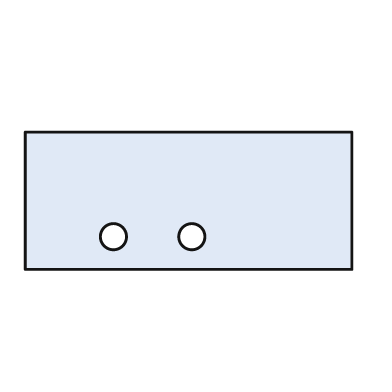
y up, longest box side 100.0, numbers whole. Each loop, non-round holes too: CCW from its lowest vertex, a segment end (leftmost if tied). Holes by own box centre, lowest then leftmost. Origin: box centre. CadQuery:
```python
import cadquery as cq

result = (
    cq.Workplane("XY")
    .moveTo(-50.0, -21.0)
    .lineTo(50.0, -21.0)
    .lineTo(50.0, 21.0)
    .lineTo(-50.0, 21.0)
    .close()
    .moveTo(-23.0, -11.0)
    .circle(4.0)
    .moveTo(1.0, -11.0)
    .circle(4.0)
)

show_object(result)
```